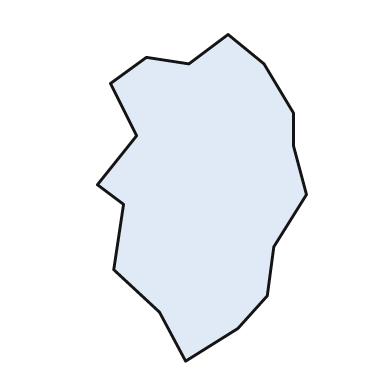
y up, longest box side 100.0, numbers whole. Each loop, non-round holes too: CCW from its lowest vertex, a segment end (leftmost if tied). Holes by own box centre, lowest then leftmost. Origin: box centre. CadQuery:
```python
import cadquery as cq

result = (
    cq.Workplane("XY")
    .moveTo(-5.0, -50.0)
    .lineTo(11.0, -40.0)
    .lineTo(20.0, -30.0)
    .lineTo(22.0, -15.0)
    .lineTo(32.0, 1.0)
    .lineTo(28.0, 16.0)
    .lineTo(28.0, 26.0)
    .lineTo(19.0, 41.0)
    .lineTo(8.0, 50.0)
    .lineTo(-4.0, 41.0)
    .lineTo(-17.0, 43.0)
    .lineTo(-28.0, 35.0)
    .lineTo(-20.0, 19.0)
    .lineTo(-32.0, 4.0)
    .lineTo(-24.0, -2.0)
    .lineTo(-27.0, -22.0)
    .lineTo(-13.0, -35.0)
    .close()
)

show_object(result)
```